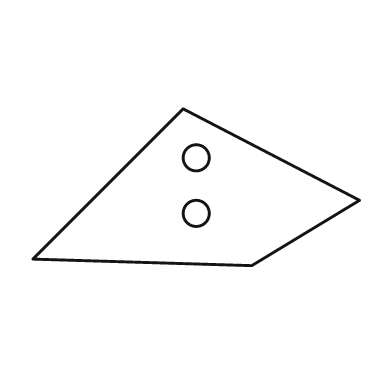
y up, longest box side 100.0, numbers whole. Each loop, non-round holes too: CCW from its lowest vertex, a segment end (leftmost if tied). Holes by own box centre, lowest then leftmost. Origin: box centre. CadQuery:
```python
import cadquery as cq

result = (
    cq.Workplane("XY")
    .moveTo(17.0, -24.0)
    .lineTo(50.0, -4.0)
    .lineTo(-4.0, 24.0)
    .lineTo(-50.0, -22.0)
    .close()
    .moveTo(0.0, -8.0)
    .circle(4.0)
    .moveTo(0.0, 9.0)
    .circle(4.0)
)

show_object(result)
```